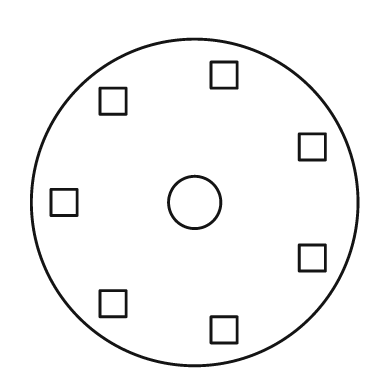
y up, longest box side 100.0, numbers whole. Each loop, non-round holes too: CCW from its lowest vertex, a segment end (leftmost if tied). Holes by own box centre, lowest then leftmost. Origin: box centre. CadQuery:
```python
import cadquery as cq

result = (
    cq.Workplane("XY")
    .moveTo(0.0, 0.0)
    .circle(50.0)
    .moveTo(5.0, -43.0)
    .lineTo(13.0, -43.0)
    .lineTo(13.0, -35.0)
    .lineTo(5.0, -35.0)
    .close()
    .moveTo(-29.0, -35.0)
    .lineTo(-21.0, -35.0)
    .lineTo(-21.0, -27.0)
    .lineTo(-29.0, -27.0)
    .close()
    .moveTo(32.0, -21.0)
    .lineTo(40.0, -21.0)
    .lineTo(40.0, -13.0)
    .lineTo(32.0, -13.0)
    .close()
    .moveTo(-44.0, -4.0)
    .lineTo(-36.0, -4.0)
    .lineTo(-36.0, 4.0)
    .lineTo(-44.0, 4.0)
    .close()
    .moveTo(0.0, 0.0)
    .circle(8.0)
    .moveTo(32.0, 13.0)
    .lineTo(40.0, 13.0)
    .lineTo(40.0, 21.0)
    .lineTo(32.0, 21.0)
    .close()
    .moveTo(-29.0, 27.0)
    .lineTo(-21.0, 27.0)
    .lineTo(-21.0, 35.0)
    .lineTo(-29.0, 35.0)
    .close()
    .moveTo(5.0, 35.0)
    .lineTo(13.0, 35.0)
    .lineTo(13.0, 43.0)
    .lineTo(5.0, 43.0)
    .close()
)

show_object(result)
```